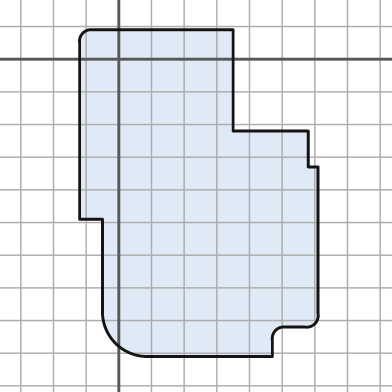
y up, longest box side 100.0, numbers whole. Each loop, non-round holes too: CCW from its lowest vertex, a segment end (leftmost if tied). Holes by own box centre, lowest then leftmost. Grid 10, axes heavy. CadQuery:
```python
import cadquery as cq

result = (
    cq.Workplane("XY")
    .moveTo(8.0, -91.0)
    .lineTo(47.0, -91.0)
    .lineTo(47.0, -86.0)
    .threePointArc((48.0, -83.0), (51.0, -82.0))
    .lineTo(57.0, -82.0)
    .threePointArc((60.0, -81.0), (61.0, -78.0))
    .lineTo(61.0, -33.0)
    .lineTo(58.0, -33.0)
    .lineTo(58.0, -22.0)
    .lineTo(35.0, -22.0)
    .lineTo(35.0, 9.0)
    .lineTo(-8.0, 9.0)
    .threePointArc((-11.0, 8.0), (-12.0, 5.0))
    .lineTo(-12.0, -49.0)
    .lineTo(-5.0, -49.0)
    .lineTo(-5.0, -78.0)
    .threePointArc((-1.0, -87.0), (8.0, -91.0))
    .close()
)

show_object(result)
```